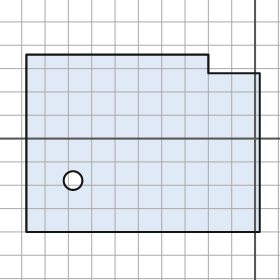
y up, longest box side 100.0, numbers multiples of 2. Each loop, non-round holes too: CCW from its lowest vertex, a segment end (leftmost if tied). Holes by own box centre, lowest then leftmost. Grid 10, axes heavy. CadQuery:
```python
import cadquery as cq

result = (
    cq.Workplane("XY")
    .moveTo(-98.0, -40.0)
    .lineTo(2.0, -40.0)
    .lineTo(2.0, 28.0)
    .lineTo(-20.0, 28.0)
    .lineTo(-20.0, 36.0)
    .lineTo(-98.0, 36.0)
    .close()
    .moveTo(-78.0, -18.0)
    .circle(4.0)
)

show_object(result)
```